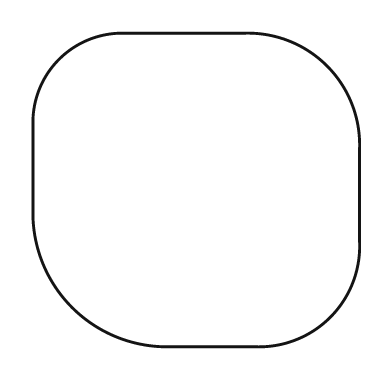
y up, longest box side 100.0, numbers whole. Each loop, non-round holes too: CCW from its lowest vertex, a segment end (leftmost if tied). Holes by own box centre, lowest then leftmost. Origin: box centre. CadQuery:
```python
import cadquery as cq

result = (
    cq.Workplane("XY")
    .moveTo(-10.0, -48.0)
    .lineTo(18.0, -48.0)
    .threePointArc((41.0, -39.0), (50.0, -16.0))
    .lineTo(50.0, 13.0)
    .threePointArc((40.0, 38.0), (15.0, 48.0))
    .lineTo(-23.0, 48.0)
    .threePointArc((-42.0, 40.0), (-50.0, 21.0))
    .lineTo(-50.0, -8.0)
    .threePointArc((-38.0, -36.0), (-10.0, -48.0))
    .close()
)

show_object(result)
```